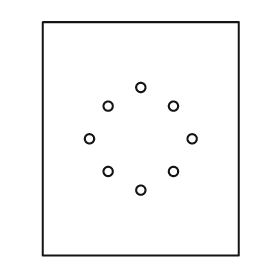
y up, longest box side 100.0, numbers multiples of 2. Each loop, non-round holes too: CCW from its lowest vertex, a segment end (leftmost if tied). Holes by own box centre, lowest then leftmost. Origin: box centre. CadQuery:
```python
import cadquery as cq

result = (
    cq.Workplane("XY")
    .moveTo(-42.0, -50.0)
    .lineTo(42.0, -50.0)
    .lineTo(42.0, 50.0)
    .lineTo(-42.0, 50.0)
    .close()
    .moveTo(0.0, -22.0)
    .circle(2.0)
    .moveTo(-14.0, -14.0)
    .circle(2.0)
    .moveTo(14.0, -14.0)
    .circle(2.0)
    .moveTo(-22.0, 0.0)
    .circle(2.0)
    .moveTo(22.0, 0.0)
    .circle(2.0)
    .moveTo(-14.0, 14.0)
    .circle(2.0)
    .moveTo(14.0, 14.0)
    .circle(2.0)
    .moveTo(0.0, 22.0)
    .circle(2.0)
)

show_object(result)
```